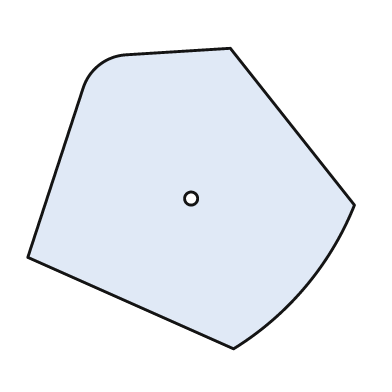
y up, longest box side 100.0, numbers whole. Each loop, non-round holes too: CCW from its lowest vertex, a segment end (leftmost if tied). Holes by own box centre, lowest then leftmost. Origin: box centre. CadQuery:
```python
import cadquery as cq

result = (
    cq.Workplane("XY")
    .moveTo(13.0, -46.0)
    .threePointArc((35.0, -27.0), (50.0, -2.0))
    .lineTo(12.0, 46.0)
    .lineTo(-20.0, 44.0)
    .threePointArc((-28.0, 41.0), (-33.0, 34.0))
    .lineTo(-50.0, -18.0)
    .close()
    .moveTo(0.0, 0.0)
    .circle(2.0)
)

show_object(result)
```